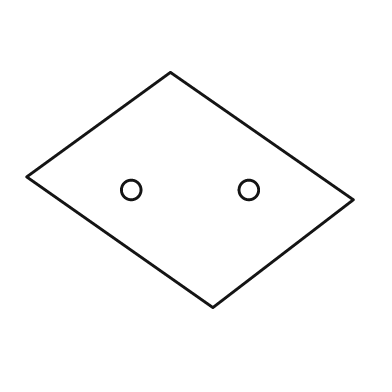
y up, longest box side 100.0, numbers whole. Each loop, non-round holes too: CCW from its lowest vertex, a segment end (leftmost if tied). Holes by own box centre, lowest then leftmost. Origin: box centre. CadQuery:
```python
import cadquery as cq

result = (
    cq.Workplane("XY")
    .moveTo(7.0, -36.0)
    .lineTo(50.0, -3.0)
    .lineTo(-6.0, 36.0)
    .lineTo(-50.0, 4.0)
    .close()
    .moveTo(-18.0, 0.0)
    .circle(3.0)
    .moveTo(18.0, 0.0)
    .circle(3.0)
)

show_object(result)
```